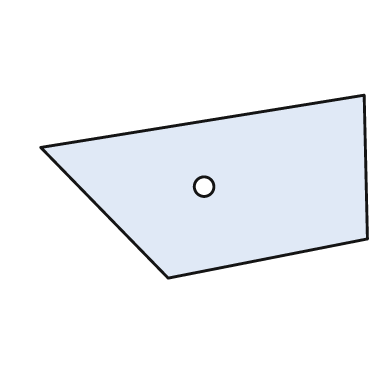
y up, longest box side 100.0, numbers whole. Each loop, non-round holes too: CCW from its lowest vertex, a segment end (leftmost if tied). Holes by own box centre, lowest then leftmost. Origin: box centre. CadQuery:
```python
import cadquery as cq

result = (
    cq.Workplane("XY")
    .moveTo(-11.0, -28.0)
    .lineTo(50.0, -16.0)
    .lineTo(49.0, 28.0)
    .lineTo(-50.0, 12.0)
    .close()
    .moveTo(0.0, 0.0)
    .circle(3.0)
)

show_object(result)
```